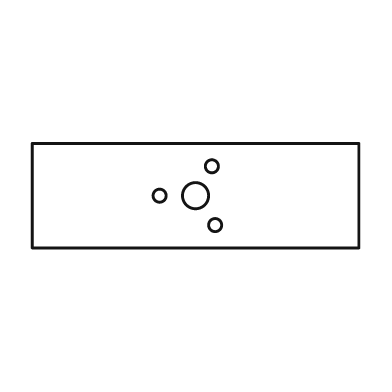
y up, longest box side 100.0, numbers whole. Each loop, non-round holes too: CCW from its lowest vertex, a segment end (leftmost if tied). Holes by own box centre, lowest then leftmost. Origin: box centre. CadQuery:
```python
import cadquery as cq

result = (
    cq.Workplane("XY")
    .moveTo(-50.0, -16.0)
    .lineTo(50.0, -16.0)
    .lineTo(50.0, 16.0)
    .lineTo(-50.0, 16.0)
    .close()
    .moveTo(6.0, -9.0)
    .circle(2.0)
    .moveTo(-11.0, 0.0)
    .circle(2.0)
    .moveTo(0.0, 0.0)
    .circle(4.0)
    .moveTo(5.0, 9.0)
    .circle(2.0)
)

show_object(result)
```